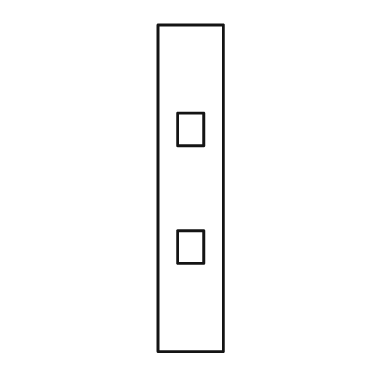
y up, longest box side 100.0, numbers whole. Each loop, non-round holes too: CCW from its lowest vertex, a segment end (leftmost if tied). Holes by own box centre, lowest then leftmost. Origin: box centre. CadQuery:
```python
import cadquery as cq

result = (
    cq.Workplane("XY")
    .moveTo(-10.0, -50.0)
    .lineTo(10.0, -50.0)
    .lineTo(10.0, 50.0)
    .lineTo(-10.0, 50.0)
    .close()
    .moveTo(-4.0, -23.0)
    .lineTo(4.0, -23.0)
    .lineTo(4.0, -13.0)
    .lineTo(-4.0, -13.0)
    .close()
    .moveTo(-4.0, 13.0)
    .lineTo(4.0, 13.0)
    .lineTo(4.0, 23.0)
    .lineTo(-4.0, 23.0)
    .close()
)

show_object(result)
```